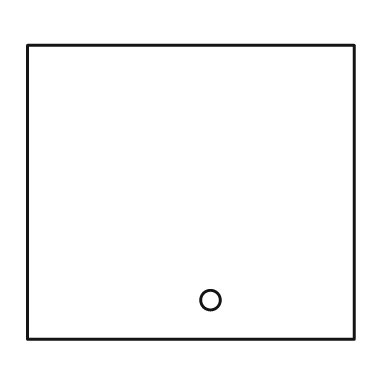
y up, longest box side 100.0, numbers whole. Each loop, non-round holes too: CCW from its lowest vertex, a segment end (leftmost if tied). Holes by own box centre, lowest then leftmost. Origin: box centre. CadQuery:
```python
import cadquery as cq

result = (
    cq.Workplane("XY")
    .moveTo(-50.0, -45.0)
    .lineTo(50.0, -45.0)
    .lineTo(50.0, 45.0)
    .lineTo(-50.0, 45.0)
    .close()
    .moveTo(6.0, -33.0)
    .circle(3.0)
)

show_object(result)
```